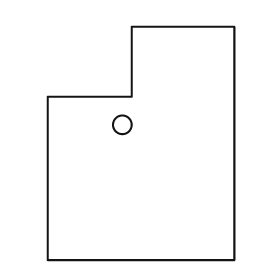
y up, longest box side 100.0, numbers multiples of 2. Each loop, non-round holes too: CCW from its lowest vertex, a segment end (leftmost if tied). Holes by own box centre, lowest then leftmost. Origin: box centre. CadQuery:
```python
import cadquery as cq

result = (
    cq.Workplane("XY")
    .moveTo(-40.0, -50.0)
    .lineTo(40.0, -50.0)
    .lineTo(40.0, 50.0)
    .lineTo(-4.0, 50.0)
    .lineTo(-4.0, 20.0)
    .lineTo(-40.0, 20.0)
    .close()
    .moveTo(-8.0, 8.0)
    .circle(4.0)
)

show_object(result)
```